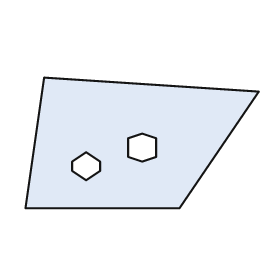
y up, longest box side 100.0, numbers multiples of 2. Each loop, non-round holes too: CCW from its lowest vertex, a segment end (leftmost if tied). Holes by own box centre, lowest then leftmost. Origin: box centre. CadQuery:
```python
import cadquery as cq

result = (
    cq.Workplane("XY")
    .moveTo(-50.0, -28.0)
    .lineTo(16.0, -28.0)
    .lineTo(50.0, 22.0)
    .lineTo(-42.0, 28.0)
    .close()
    .moveTo(-24.0, -16.0)
    .lineTo(-18.0, -12.0)
    .lineTo(-18.0, -8.0)
    .lineTo(-24.0, -4.0)
    .lineTo(-30.0, -8.0)
    .lineTo(-30.0, -12.0)
    .close()
    .moveTo(0.0, -8.0)
    .lineTo(6.0, -6.0)
    .lineTo(6.0, 2.0)
    .lineTo(0.0, 4.0)
    .lineTo(-6.0, 2.0)
    .lineTo(-6.0, -6.0)
    .close()
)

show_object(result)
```